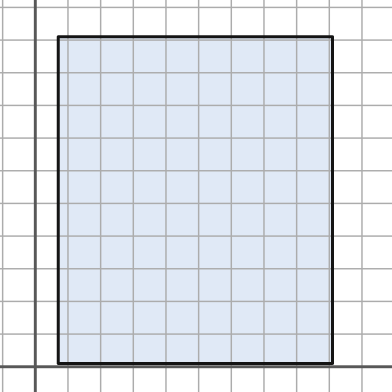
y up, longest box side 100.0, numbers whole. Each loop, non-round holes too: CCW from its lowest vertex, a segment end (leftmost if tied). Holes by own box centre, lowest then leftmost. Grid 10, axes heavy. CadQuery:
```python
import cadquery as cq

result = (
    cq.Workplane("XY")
    .moveTo(7.0, 1.0)
    .lineTo(91.0, 1.0)
    .lineTo(91.0, 101.0)
    .lineTo(7.0, 101.0)
    .close()
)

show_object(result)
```